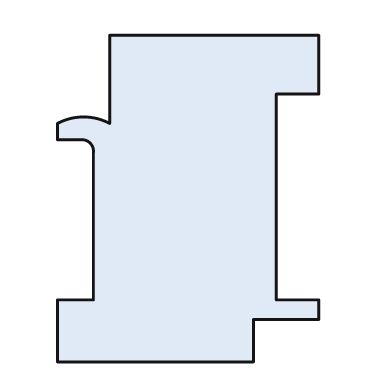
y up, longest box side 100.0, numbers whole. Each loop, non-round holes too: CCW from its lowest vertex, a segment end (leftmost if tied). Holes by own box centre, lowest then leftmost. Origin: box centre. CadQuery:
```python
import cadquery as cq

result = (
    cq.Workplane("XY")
    .moveTo(-40.0, -50.0)
    .lineTo(20.0, -50.0)
    .lineTo(20.0, -37.0)
    .lineTo(40.0, -37.0)
    .lineTo(40.0, -31.0)
    .lineTo(27.0, -31.0)
    .lineTo(27.0, 32.0)
    .lineTo(40.0, 32.0)
    .lineTo(40.0, 50.0)
    .lineTo(-24.0, 50.0)
    .lineTo(-24.0, 23.0)
    .threePointArc((-32.0, 25.0), (-40.0, 23.0))
    .lineTo(-40.0, 18.0)
    .lineTo(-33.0, 18.0)
    .threePointArc((-30.0, 17.0), (-29.0, 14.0))
    .lineTo(-29.0, -31.0)
    .lineTo(-40.0, -31.0)
    .close()
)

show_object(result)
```